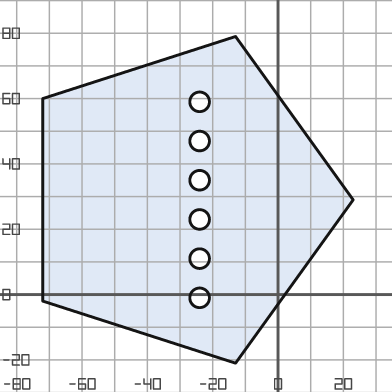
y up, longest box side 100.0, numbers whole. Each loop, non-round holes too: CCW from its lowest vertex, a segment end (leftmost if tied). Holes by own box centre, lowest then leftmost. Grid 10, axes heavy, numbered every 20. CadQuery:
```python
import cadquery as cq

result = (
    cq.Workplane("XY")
    .moveTo(-13.0, -21.0)
    .lineTo(23.0, 29.0)
    .lineTo(-13.0, 79.0)
    .lineTo(-72.0, 60.0)
    .lineTo(-72.0, -2.0)
    .close()
    .moveTo(-24.0, -1.0)
    .circle(3.0)
    .moveTo(-24.0, 11.0)
    .circle(3.0)
    .moveTo(-24.0, 23.0)
    .circle(3.0)
    .moveTo(-24.0, 35.0)
    .circle(3.0)
    .moveTo(-24.0, 47.0)
    .circle(3.0)
    .moveTo(-24.0, 59.0)
    .circle(3.0)
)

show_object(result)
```